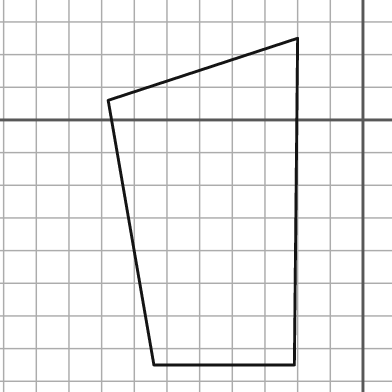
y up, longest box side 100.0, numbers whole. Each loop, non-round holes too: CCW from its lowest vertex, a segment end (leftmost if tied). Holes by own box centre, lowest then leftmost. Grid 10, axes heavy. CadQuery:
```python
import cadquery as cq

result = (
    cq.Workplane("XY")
    .moveTo(-64.0, -75.0)
    .lineTo(-21.0, -75.0)
    .lineTo(-20.0, 25.0)
    .lineTo(-78.0, 6.0)
    .close()
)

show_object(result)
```